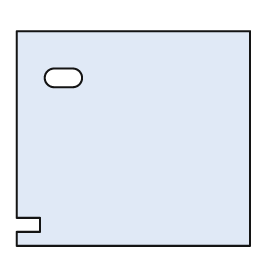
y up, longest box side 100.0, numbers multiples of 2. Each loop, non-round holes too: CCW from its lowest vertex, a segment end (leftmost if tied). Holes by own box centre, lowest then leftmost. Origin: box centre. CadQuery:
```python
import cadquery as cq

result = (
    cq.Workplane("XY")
    .moveTo(-50.0, -46.0)
    .lineTo(50.0, -46.0)
    .lineTo(50.0, 46.0)
    .lineTo(-50.0, 46.0)
    .lineTo(-50.0, -34.0)
    .lineTo(-40.0, -34.0)
    .lineTo(-40.0, -40.0)
    .lineTo(-50.0, -40.0)
    .close()
    .moveTo(-34.0, 22.0)
    .lineTo(-26.0, 22.0)
    .threePointArc((-22.0, 26.0), (-26.0, 30.0))
    .lineTo(-34.0, 30.0)
    .threePointArc((-38.0, 26.0), (-34.0, 22.0))
    .close()
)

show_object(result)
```